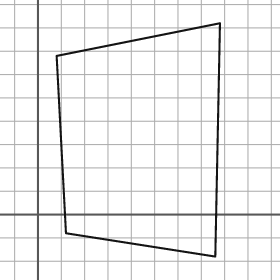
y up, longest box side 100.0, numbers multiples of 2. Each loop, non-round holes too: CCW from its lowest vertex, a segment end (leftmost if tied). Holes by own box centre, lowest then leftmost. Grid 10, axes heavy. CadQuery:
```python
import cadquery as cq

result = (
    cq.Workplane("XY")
    .moveTo(76.0, -18.0)
    .lineTo(78.0, 82.0)
    .lineTo(8.0, 68.0)
    .lineTo(12.0, -8.0)
    .close()
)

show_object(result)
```